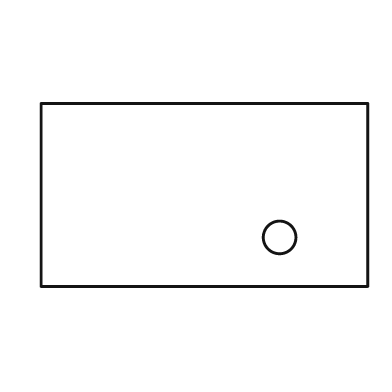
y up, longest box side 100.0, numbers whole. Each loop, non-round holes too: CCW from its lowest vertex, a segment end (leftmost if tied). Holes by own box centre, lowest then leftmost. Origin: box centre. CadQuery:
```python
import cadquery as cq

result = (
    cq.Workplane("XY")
    .moveTo(-50.0, -28.0)
    .lineTo(50.0, -28.0)
    .lineTo(50.0, 28.0)
    .lineTo(-50.0, 28.0)
    .close()
    .moveTo(23.0, -13.0)
    .circle(5.0)
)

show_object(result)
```